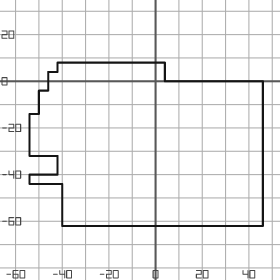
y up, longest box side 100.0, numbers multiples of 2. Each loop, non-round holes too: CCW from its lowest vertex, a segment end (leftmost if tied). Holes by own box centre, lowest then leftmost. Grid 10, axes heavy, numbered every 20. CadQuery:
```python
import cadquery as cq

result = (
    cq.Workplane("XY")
    .moveTo(-40.0, -62.0)
    .lineTo(46.0, -62.0)
    .lineTo(46.0, 0.0)
    .lineTo(4.0, 0.0)
    .lineTo(4.0, 8.0)
    .lineTo(-42.0, 8.0)
    .lineTo(-42.0, 4.0)
    .lineTo(-46.0, 4.0)
    .lineTo(-46.0, -4.0)
    .lineTo(-50.0, -4.0)
    .lineTo(-50.0, -14.0)
    .lineTo(-54.0, -14.0)
    .lineTo(-54.0, -32.0)
    .lineTo(-42.0, -32.0)
    .lineTo(-42.0, -40.0)
    .lineTo(-54.0, -40.0)
    .lineTo(-54.0, -44.0)
    .lineTo(-40.0, -44.0)
    .close()
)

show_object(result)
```